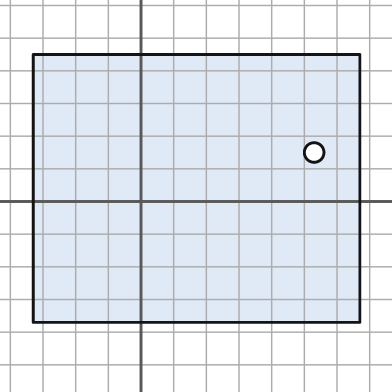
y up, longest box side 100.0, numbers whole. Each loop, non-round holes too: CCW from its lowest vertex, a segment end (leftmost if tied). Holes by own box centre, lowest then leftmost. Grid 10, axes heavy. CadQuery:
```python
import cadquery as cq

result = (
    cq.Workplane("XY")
    .moveTo(-33.0, -37.0)
    .lineTo(67.0, -37.0)
    .lineTo(67.0, 45.0)
    .lineTo(-33.0, 45.0)
    .close()
    .moveTo(53.0, 15.0)
    .circle(3.0)
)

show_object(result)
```